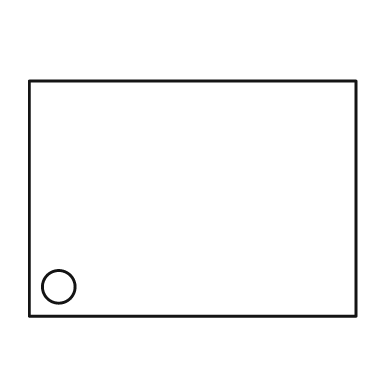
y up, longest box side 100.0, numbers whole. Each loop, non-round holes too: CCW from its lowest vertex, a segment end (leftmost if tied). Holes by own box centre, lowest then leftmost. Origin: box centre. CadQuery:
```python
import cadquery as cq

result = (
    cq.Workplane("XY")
    .moveTo(-50.0, -36.0)
    .lineTo(50.0, -36.0)
    .lineTo(50.0, 36.0)
    .lineTo(-50.0, 36.0)
    .close()
    .moveTo(-41.0, -27.0)
    .circle(5.0)
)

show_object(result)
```